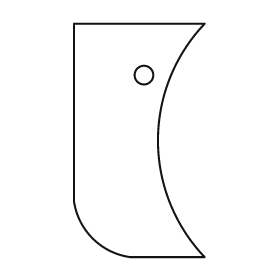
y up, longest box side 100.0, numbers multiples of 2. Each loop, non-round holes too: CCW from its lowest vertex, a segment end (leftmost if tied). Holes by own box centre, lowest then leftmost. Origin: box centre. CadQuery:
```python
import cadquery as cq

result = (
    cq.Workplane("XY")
    .moveTo(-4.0, -50.0)
    .lineTo(28.0, -50.0)
    .threePointArc((8.0, 0.0), (28.0, 50.0))
    .lineTo(-28.0, 50.0)
    .lineTo(-28.0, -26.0)
    .threePointArc((-20.0, -42.0), (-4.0, -50.0))
    .close()
    .moveTo(2.0, 28.0)
    .circle(4.0)
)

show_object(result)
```